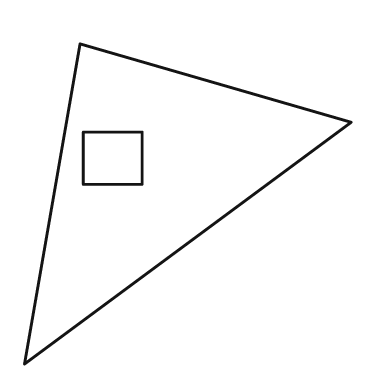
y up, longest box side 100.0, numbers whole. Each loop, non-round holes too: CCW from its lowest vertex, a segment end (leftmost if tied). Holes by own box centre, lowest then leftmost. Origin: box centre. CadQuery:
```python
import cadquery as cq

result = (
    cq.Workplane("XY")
    .moveTo(-50.0, -49.0)
    .lineTo(50.0, 25.0)
    .lineTo(-33.0, 49.0)
    .close()
    .moveTo(-32.0, 6.0)
    .lineTo(-14.0, 6.0)
    .lineTo(-14.0, 22.0)
    .lineTo(-32.0, 22.0)
    .close()
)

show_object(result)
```